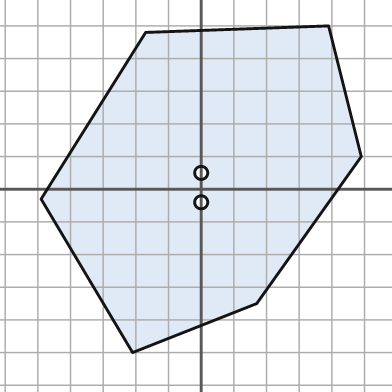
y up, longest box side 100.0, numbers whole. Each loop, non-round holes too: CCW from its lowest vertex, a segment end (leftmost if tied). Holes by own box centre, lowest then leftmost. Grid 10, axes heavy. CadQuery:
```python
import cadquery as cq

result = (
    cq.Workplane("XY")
    .moveTo(-21.0, -50.0)
    .lineTo(17.0, -35.0)
    .lineTo(49.0, 10.0)
    .lineTo(39.0, 50.0)
    .lineTo(-17.0, 48.0)
    .lineTo(-49.0, -3.0)
    .close()
    .moveTo(0.0, -4.0)
    .circle(2.0)
    .moveTo(0.0, 5.0)
    .circle(2.0)
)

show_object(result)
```